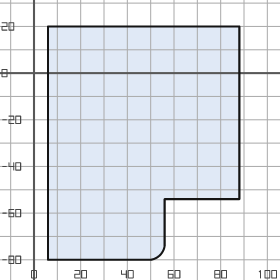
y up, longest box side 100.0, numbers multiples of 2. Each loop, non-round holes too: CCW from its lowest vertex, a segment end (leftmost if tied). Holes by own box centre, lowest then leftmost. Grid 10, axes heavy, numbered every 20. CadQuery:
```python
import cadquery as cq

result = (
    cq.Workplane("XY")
    .moveTo(6.0, -80.0)
    .lineTo(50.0, -80.0)
    .threePointArc((54.0, -78.0), (56.0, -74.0))
    .lineTo(56.0, -54.0)
    .lineTo(88.0, -54.0)
    .lineTo(88.0, 20.0)
    .lineTo(6.0, 20.0)
    .close()
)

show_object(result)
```